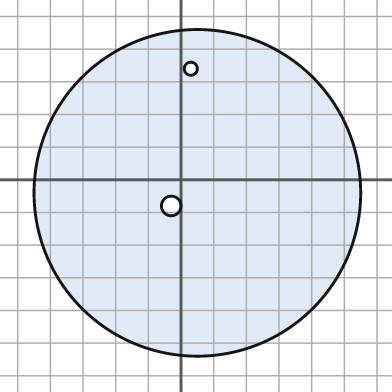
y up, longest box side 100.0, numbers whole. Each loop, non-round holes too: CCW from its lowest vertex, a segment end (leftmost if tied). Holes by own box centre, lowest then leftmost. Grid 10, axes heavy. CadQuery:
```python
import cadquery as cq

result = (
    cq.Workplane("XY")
    .moveTo(5.0, -4.0)
    .circle(50.0)
    .moveTo(-3.0, -8.0)
    .circle(3.0)
    .moveTo(3.0, 34.0)
    .circle(2.0)
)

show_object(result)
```